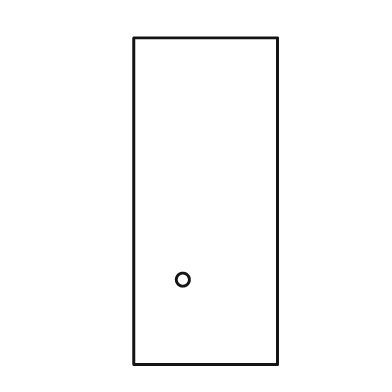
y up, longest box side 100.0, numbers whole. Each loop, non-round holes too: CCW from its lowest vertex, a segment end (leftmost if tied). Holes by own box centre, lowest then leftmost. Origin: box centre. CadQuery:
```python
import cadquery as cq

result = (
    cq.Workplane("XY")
    .moveTo(-22.0, -50.0)
    .lineTo(22.0, -50.0)
    .lineTo(22.0, 50.0)
    .lineTo(-22.0, 50.0)
    .close()
    .moveTo(-7.0, -24.0)
    .circle(2.0)
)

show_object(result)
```